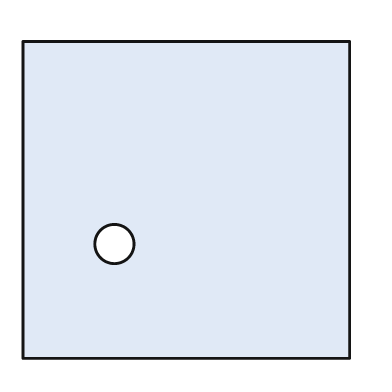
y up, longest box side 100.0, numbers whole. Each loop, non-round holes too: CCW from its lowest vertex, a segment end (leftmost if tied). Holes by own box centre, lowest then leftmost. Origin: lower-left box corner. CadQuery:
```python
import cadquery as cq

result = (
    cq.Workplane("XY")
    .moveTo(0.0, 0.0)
    .lineTo(100.0, 0.0)
    .lineTo(100.0, 97.0)
    .lineTo(0.0, 97.0)
    .close()
    .moveTo(28.0, 35.0)
    .circle(6.0)
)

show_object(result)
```